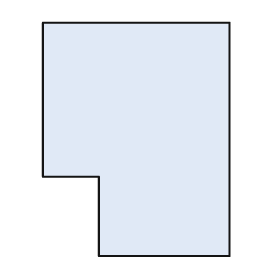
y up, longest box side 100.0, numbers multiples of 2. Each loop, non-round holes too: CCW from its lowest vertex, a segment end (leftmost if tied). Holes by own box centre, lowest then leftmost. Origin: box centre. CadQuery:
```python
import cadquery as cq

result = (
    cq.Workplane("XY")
    .moveTo(-16.0, -50.0)
    .lineTo(40.0, -50.0)
    .lineTo(40.0, 50.0)
    .lineTo(-40.0, 50.0)
    .lineTo(-40.0, -16.0)
    .lineTo(-16.0, -16.0)
    .close()
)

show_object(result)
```